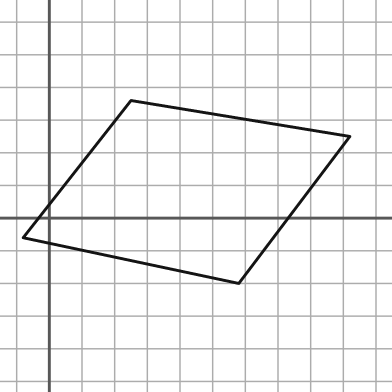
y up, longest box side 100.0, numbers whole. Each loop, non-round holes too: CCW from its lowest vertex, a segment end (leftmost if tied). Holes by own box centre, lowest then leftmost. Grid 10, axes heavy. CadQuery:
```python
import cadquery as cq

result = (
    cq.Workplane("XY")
    .moveTo(58.0, -20.0)
    .lineTo(92.0, 25.0)
    .lineTo(25.0, 36.0)
    .lineTo(-8.0, -6.0)
    .close()
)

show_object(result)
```